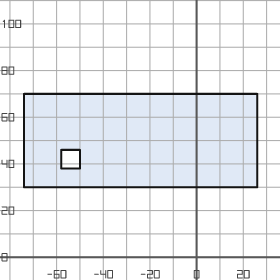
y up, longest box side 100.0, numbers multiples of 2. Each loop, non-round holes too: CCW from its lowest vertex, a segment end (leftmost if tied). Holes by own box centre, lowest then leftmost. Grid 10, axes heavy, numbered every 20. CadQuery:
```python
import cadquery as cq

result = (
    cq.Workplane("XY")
    .moveTo(-74.0, 30.0)
    .lineTo(26.0, 30.0)
    .lineTo(26.0, 70.0)
    .lineTo(-74.0, 70.0)
    .close()
    .moveTo(-58.0, 38.0)
    .lineTo(-50.0, 38.0)
    .lineTo(-50.0, 46.0)
    .lineTo(-58.0, 46.0)
    .close()
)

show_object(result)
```